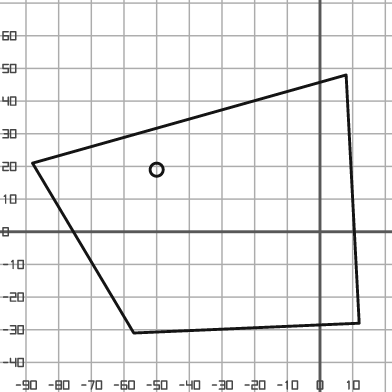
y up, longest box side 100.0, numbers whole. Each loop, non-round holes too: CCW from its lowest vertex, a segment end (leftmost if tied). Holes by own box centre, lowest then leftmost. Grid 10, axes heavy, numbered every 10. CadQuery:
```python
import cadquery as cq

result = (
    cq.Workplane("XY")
    .moveTo(-57.0, -31.0)
    .lineTo(12.0, -28.0)
    .lineTo(8.0, 48.0)
    .lineTo(-88.0, 21.0)
    .close()
    .moveTo(-50.0, 19.0)
    .circle(2.0)
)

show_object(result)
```